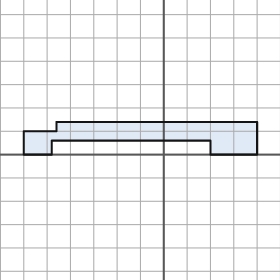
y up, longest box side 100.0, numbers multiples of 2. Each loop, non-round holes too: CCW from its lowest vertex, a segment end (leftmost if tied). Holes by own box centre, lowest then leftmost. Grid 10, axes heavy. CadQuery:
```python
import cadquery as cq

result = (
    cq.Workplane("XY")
    .moveTo(-60.0, 0.0)
    .lineTo(-48.0, 0.0)
    .lineTo(-48.0, 6.0)
    .lineTo(20.0, 6.0)
    .lineTo(20.0, 0.0)
    .lineTo(40.0, 0.0)
    .lineTo(40.0, 14.0)
    .lineTo(-46.0, 14.0)
    .lineTo(-46.0, 10.0)
    .lineTo(-60.0, 10.0)
    .close()
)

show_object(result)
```